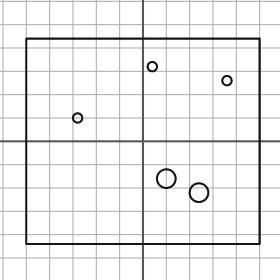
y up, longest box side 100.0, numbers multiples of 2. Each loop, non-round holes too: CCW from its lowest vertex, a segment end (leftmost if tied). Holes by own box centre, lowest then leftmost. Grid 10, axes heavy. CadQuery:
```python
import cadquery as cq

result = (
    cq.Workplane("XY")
    .moveTo(-50.0, -44.0)
    .lineTo(50.0, -44.0)
    .lineTo(50.0, 44.0)
    .lineTo(-50.0, 44.0)
    .close()
    .moveTo(24.0, -22.0)
    .circle(4.0)
    .moveTo(10.0, -16.0)
    .circle(4.0)
    .moveTo(-28.0, 10.0)
    .circle(2.0)
    .moveTo(36.0, 26.0)
    .circle(2.0)
    .moveTo(4.0, 32.0)
    .circle(2.0)
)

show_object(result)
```